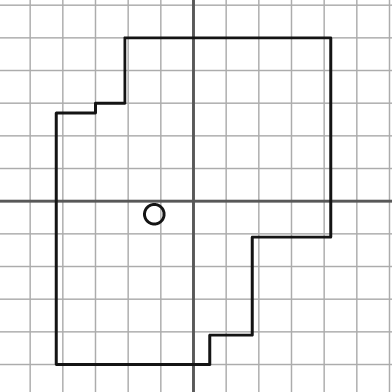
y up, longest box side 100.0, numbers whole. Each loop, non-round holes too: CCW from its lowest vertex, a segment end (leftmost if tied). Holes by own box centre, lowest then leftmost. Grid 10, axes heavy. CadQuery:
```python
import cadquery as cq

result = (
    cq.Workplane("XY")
    .moveTo(-42.0, -50.0)
    .lineTo(5.0, -50.0)
    .lineTo(5.0, -41.0)
    .lineTo(18.0, -41.0)
    .lineTo(18.0, -11.0)
    .lineTo(42.0, -11.0)
    .lineTo(42.0, 50.0)
    .lineTo(-21.0, 50.0)
    .lineTo(-21.0, 30.0)
    .lineTo(-30.0, 30.0)
    .lineTo(-30.0, 27.0)
    .lineTo(-42.0, 27.0)
    .close()
    .moveTo(-12.0, -4.0)
    .circle(3.0)
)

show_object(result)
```